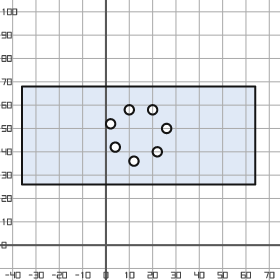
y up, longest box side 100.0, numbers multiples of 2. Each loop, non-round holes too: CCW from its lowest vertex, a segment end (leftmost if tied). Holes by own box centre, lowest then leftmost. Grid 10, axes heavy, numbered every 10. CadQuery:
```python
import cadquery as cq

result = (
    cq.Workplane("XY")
    .moveTo(-36.0, 26.0)
    .lineTo(64.0, 26.0)
    .lineTo(64.0, 68.0)
    .lineTo(-36.0, 68.0)
    .close()
    .moveTo(12.0, 36.0)
    .circle(2.0)
    .moveTo(22.0, 40.0)
    .circle(2.0)
    .moveTo(4.0, 42.0)
    .circle(2.0)
    .moveTo(26.0, 50.0)
    .circle(2.0)
    .moveTo(2.0, 52.0)
    .circle(2.0)
    .moveTo(10.0, 58.0)
    .circle(2.0)
    .moveTo(20.0, 58.0)
    .circle(2.0)
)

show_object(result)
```